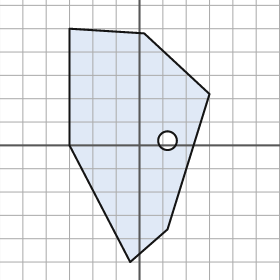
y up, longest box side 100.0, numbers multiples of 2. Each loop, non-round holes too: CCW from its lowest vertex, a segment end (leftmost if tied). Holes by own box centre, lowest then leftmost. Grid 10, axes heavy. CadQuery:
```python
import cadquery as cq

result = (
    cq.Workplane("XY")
    .moveTo(-4.0, -50.0)
    .lineTo(12.0, -36.0)
    .lineTo(30.0, 22.0)
    .lineTo(2.0, 48.0)
    .lineTo(-30.0, 50.0)
    .lineTo(-30.0, 0.0)
    .close()
    .moveTo(12.0, 2.0)
    .circle(4.0)
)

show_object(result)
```